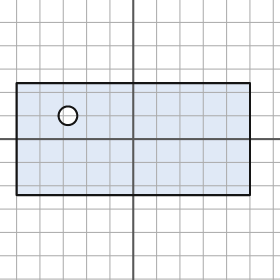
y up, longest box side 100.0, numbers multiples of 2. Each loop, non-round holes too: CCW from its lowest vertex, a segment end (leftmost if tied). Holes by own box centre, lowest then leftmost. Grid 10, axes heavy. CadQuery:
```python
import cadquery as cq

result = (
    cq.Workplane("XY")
    .moveTo(-50.0, -24.0)
    .lineTo(50.0, -24.0)
    .lineTo(50.0, 24.0)
    .lineTo(-50.0, 24.0)
    .close()
    .moveTo(-28.0, 10.0)
    .circle(4.0)
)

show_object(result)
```